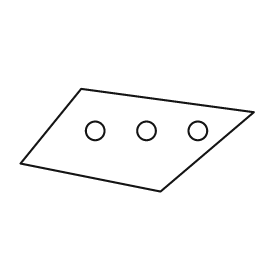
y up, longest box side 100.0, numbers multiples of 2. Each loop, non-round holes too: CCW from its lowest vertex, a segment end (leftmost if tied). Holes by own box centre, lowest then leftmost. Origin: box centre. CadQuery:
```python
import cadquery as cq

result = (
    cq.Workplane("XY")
    .moveTo(10.0, -22.0)
    .lineTo(50.0, 12.0)
    .lineTo(-24.0, 22.0)
    .lineTo(-50.0, -10.0)
    .close()
    .moveTo(-18.0, 4.0)
    .circle(4.0)
    .moveTo(4.0, 4.0)
    .circle(4.0)
    .moveTo(26.0, 4.0)
    .circle(4.0)
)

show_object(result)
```